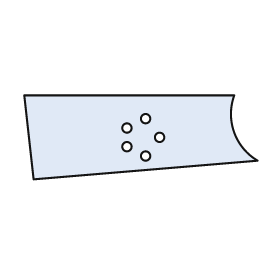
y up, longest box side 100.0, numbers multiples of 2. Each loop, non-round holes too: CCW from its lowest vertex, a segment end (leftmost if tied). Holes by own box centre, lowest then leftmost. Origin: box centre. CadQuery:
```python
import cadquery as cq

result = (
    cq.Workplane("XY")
    .moveTo(-46.0, -18.0)
    .lineTo(50.0, -10.0)
    .threePointArc((40.0, 2.0), (40.0, 18.0))
    .lineTo(-50.0, 18.0)
    .close()
    .moveTo(2.0, -8.0)
    .circle(2.0)
    .moveTo(-6.0, -4.0)
    .circle(2.0)
    .moveTo(8.0, 0.0)
    .circle(2.0)
    .moveTo(-6.0, 4.0)
    .circle(2.0)
    .moveTo(2.0, 8.0)
    .circle(2.0)
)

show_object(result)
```